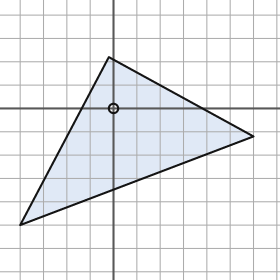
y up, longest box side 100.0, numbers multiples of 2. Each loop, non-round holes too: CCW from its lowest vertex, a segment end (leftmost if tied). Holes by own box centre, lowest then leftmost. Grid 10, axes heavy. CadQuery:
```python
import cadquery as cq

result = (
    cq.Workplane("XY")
    .moveTo(-40.0, -50.0)
    .lineTo(60.0, -12.0)
    .lineTo(-2.0, 22.0)
    .close()
    .moveTo(0.0, 0.0)
    .circle(2.0)
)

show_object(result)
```